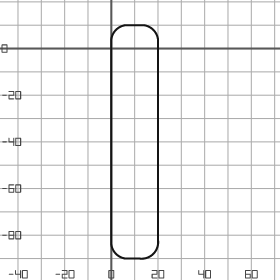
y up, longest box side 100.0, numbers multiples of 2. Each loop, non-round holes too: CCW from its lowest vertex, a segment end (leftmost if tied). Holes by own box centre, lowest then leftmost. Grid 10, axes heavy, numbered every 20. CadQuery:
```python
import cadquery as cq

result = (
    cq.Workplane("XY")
    .moveTo(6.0, -90.0)
    .lineTo(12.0, -90.0)
    .threePointArc((18.0, -88.0), (20.0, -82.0))
    .lineTo(20.0, 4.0)
    .threePointArc((18.0, 8.0), (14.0, 10.0))
    .lineTo(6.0, 10.0)
    .threePointArc((2.0, 8.0), (0.0, 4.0))
    .lineTo(0.0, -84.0)
    .threePointArc((2.0, -88.0), (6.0, -90.0))
    .close()
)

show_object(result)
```